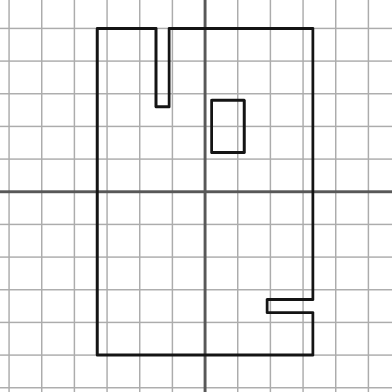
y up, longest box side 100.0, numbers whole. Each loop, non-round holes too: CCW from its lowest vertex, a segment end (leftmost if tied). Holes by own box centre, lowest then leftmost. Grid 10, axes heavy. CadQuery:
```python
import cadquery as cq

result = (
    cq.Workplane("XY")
    .moveTo(-33.0, -50.0)
    .lineTo(33.0, -50.0)
    .lineTo(33.0, -37.0)
    .lineTo(19.0, -37.0)
    .lineTo(19.0, -33.0)
    .lineTo(33.0, -33.0)
    .lineTo(33.0, 50.0)
    .lineTo(-11.0, 50.0)
    .lineTo(-11.0, 26.0)
    .lineTo(-15.0, 26.0)
    .lineTo(-15.0, 50.0)
    .lineTo(-33.0, 50.0)
    .close()
    .moveTo(2.0, 12.0)
    .lineTo(12.0, 12.0)
    .lineTo(12.0, 28.0)
    .lineTo(2.0, 28.0)
    .close()
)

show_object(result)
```